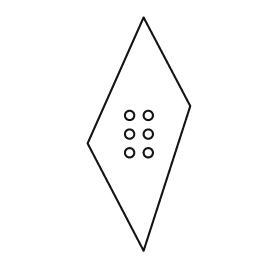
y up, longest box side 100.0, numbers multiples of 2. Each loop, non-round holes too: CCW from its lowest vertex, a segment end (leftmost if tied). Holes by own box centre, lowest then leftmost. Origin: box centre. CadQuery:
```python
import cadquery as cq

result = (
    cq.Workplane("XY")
    .moveTo(2.0, -50.0)
    .lineTo(22.0, 12.0)
    .lineTo(2.0, 50.0)
    .lineTo(-22.0, -4.0)
    .close()
    .moveTo(-4.0, -8.0)
    .circle(2.0)
    .moveTo(4.0, -8.0)
    .circle(2.0)
    .moveTo(-4.0, 0.0)
    .circle(2.0)
    .moveTo(4.0, 0.0)
    .circle(2.0)
    .moveTo(-4.0, 8.0)
    .circle(2.0)
    .moveTo(4.0, 8.0)
    .circle(2.0)
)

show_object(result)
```